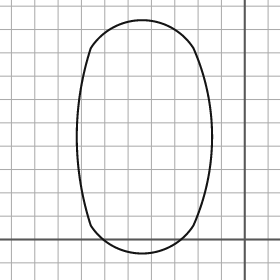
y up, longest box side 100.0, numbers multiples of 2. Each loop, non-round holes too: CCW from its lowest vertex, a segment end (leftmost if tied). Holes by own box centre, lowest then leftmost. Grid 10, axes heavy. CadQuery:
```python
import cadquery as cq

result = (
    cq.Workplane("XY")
    .moveTo(-66.0, 6.0)
    .threePointArc((-44.0, -6.0), (-22.0, 6.0))
    .threePointArc((-14.0, 44.0), (-22.0, 82.0))
    .threePointArc((-44.0, 94.0), (-66.0, 82.0))
    .threePointArc((-72.0, 44.0), (-66.0, 6.0))
    .close()
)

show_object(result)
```